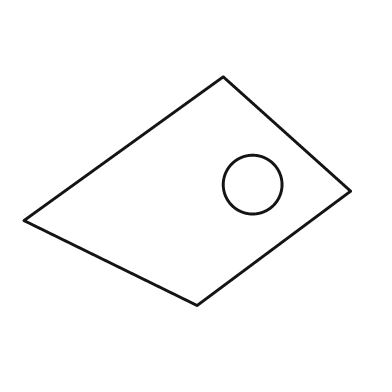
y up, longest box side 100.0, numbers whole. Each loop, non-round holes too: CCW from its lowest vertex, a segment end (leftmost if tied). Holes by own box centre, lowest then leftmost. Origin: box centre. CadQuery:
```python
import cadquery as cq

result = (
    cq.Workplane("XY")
    .moveTo(3.0, -35.0)
    .lineTo(50.0, 0.0)
    .lineTo(11.0, 35.0)
    .lineTo(-50.0, -9.0)
    .close()
    .moveTo(20.0, 2.0)
    .circle(9.0)
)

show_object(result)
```